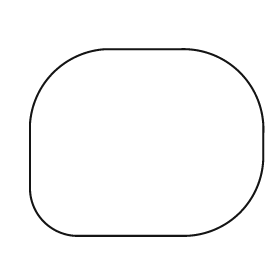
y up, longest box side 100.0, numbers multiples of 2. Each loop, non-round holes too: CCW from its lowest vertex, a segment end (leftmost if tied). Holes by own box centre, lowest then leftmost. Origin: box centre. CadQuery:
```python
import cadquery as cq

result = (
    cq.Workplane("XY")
    .moveTo(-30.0, -40.0)
    .lineTo(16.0, -40.0)
    .threePointArc((40.0, -30.0), (50.0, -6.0))
    .lineTo(50.0, 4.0)
    .threePointArc((40.0, 30.0), (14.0, 40.0))
    .lineTo(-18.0, 40.0)
    .threePointArc((-40.0, 30.0), (-50.0, 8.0))
    .lineTo(-50.0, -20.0)
    .threePointArc((-44.0, -34.0), (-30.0, -40.0))
    .close()
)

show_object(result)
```